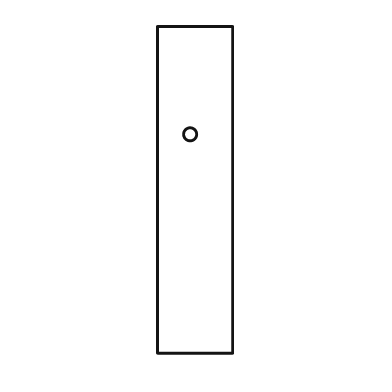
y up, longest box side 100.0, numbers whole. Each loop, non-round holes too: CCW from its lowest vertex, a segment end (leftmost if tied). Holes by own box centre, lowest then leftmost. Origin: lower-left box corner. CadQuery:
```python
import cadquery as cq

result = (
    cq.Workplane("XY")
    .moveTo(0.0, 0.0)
    .lineTo(23.0, 0.0)
    .lineTo(23.0, 100.0)
    .lineTo(0.0, 100.0)
    .close()
    .moveTo(10.0, 67.0)
    .circle(2.0)
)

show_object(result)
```